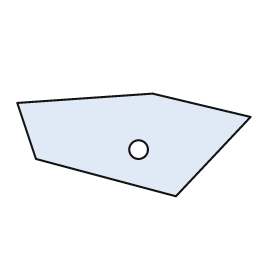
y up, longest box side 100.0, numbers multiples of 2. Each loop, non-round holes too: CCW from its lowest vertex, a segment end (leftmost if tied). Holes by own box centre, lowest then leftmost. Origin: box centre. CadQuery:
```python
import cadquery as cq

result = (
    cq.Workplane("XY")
    .moveTo(18.0, -22.0)
    .lineTo(50.0, 12.0)
    .lineTo(8.0, 22.0)
    .lineTo(-50.0, 18.0)
    .lineTo(-42.0, -6.0)
    .close()
    .moveTo(2.0, -2.0)
    .circle(4.0)
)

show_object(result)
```